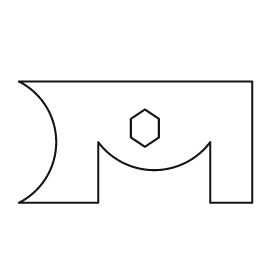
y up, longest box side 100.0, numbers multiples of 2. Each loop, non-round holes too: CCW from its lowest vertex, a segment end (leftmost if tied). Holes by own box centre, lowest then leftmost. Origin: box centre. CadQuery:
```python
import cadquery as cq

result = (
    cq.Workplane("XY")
    .moveTo(-50.0, -26.0)
    .lineTo(-16.0, -26.0)
    .lineTo(-16.0, 0.0)
    .threePointArc((8.0, -12.0), (32.0, 0.0))
    .lineTo(32.0, -26.0)
    .lineTo(50.0, -26.0)
    .lineTo(50.0, 26.0)
    .lineTo(-50.0, 26.0)
    .threePointArc((-34.0, 0.0), (-50.0, -26.0))
    .close()
    .moveTo(4.0, -2.0)
    .lineTo(10.0, 2.0)
    .lineTo(10.0, 10.0)
    .lineTo(4.0, 14.0)
    .lineTo(-2.0, 10.0)
    .lineTo(-2.0, 2.0)
    .close()
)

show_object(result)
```